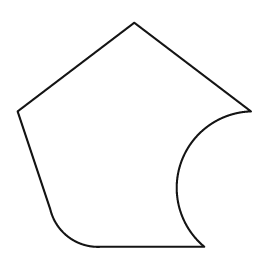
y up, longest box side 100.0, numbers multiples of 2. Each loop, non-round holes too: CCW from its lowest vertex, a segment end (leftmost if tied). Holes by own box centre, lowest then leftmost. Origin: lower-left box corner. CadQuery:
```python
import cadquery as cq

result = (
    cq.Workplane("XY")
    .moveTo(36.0, 0.0)
    .lineTo(80.0, 0.0)
    .threePointArc((70.0, 36.0), (100.0, 58.0))
    .lineTo(50.0, 96.0)
    .lineTo(0.0, 58.0)
    .lineTo(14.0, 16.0)
    .threePointArc((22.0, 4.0), (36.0, 0.0))
    .close()
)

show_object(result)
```